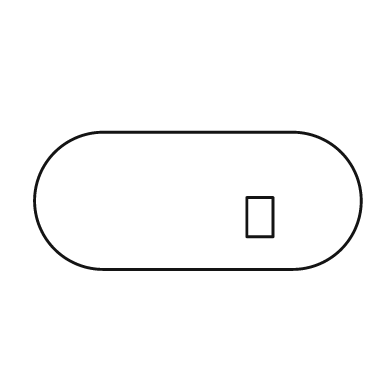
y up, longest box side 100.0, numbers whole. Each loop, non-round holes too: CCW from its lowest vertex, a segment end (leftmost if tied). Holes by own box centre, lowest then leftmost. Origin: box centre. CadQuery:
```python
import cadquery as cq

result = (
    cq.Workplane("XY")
    .moveTo(-29.0, -21.0)
    .lineTo(29.0, -21.0)
    .threePointArc((50.0, 0.0), (29.0, 21.0))
    .lineTo(-29.0, 21.0)
    .threePointArc((-50.0, 0.0), (-29.0, -21.0))
    .close()
    .moveTo(15.0, -11.0)
    .lineTo(23.0, -11.0)
    .lineTo(23.0, 1.0)
    .lineTo(15.0, 1.0)
    .close()
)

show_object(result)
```